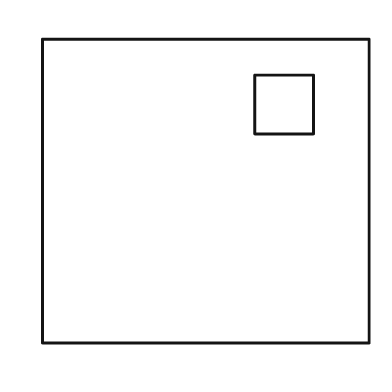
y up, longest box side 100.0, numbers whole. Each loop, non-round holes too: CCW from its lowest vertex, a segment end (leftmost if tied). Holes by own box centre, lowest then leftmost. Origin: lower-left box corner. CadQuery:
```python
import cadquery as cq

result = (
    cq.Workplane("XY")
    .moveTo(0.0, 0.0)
    .lineTo(100.0, 0.0)
    .lineTo(100.0, 93.0)
    .lineTo(0.0, 93.0)
    .close()
    .moveTo(65.0, 64.0)
    .lineTo(83.0, 64.0)
    .lineTo(83.0, 82.0)
    .lineTo(65.0, 82.0)
    .close()
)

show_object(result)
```